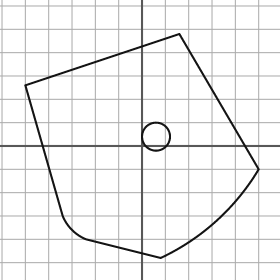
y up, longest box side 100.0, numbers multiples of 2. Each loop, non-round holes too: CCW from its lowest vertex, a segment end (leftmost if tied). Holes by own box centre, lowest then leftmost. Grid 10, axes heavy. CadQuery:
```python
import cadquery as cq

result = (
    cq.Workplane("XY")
    .moveTo(8.0, -48.0)
    .threePointArc((32.0, -32.0), (50.0, -10.0))
    .lineTo(16.0, 48.0)
    .lineTo(-50.0, 26.0)
    .lineTo(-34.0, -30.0)
    .threePointArc((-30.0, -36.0), (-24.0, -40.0))
    .close()
    .moveTo(6.0, 4.0)
    .circle(6.0)
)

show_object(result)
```